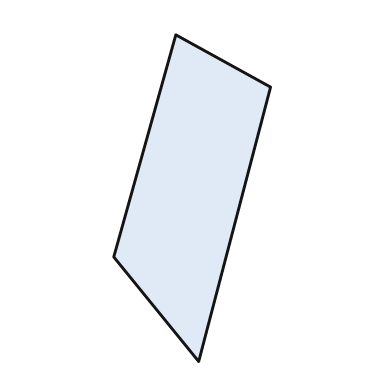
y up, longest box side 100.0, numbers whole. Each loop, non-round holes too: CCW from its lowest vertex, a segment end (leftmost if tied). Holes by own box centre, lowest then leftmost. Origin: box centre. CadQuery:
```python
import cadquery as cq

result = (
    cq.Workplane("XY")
    .moveTo(2.0, -50.0)
    .lineTo(24.0, 34.0)
    .lineTo(-5.0, 50.0)
    .lineTo(-24.0, -18.0)
    .close()
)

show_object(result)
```